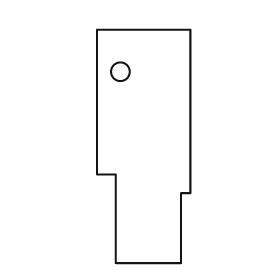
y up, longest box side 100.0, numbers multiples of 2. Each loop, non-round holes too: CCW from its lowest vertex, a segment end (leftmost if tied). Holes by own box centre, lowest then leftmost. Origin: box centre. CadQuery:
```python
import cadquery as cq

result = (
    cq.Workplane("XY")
    .moveTo(-12.0, -50.0)
    .lineTo(16.0, -50.0)
    .lineTo(16.0, -20.0)
    .lineTo(20.0, -20.0)
    .lineTo(20.0, 50.0)
    .lineTo(-20.0, 50.0)
    .lineTo(-20.0, -12.0)
    .lineTo(-12.0, -12.0)
    .close()
    .moveTo(-10.0, 32.0)
    .circle(4.0)
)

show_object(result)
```